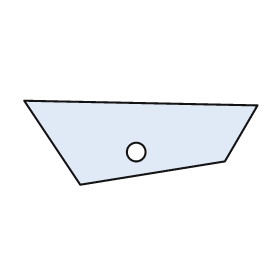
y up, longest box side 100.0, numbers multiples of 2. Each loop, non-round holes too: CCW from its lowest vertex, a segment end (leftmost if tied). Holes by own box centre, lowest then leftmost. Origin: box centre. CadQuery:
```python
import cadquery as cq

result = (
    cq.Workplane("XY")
    .moveTo(-26.0, -18.0)
    .lineTo(36.0, -8.0)
    .lineTo(50.0, 16.0)
    .lineTo(-50.0, 18.0)
    .close()
    .moveTo(-2.0, -4.0)
    .circle(4.0)
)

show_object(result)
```